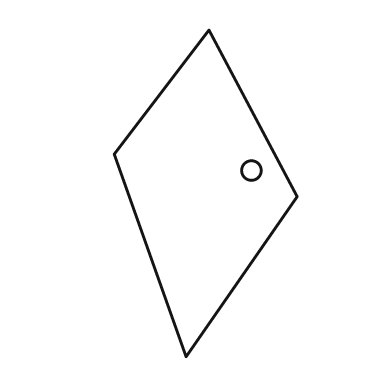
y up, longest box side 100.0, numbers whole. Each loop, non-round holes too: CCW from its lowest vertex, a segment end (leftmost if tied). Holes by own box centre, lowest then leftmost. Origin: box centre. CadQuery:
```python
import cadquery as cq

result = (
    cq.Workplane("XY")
    .moveTo(-6.0, -50.0)
    .lineTo(28.0, -1.0)
    .lineTo(1.0, 50.0)
    .lineTo(-28.0, 12.0)
    .close()
    .moveTo(14.0, 7.0)
    .circle(3.0)
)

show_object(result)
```